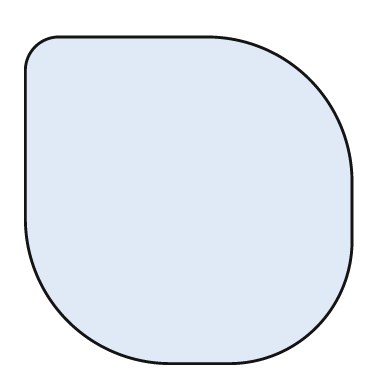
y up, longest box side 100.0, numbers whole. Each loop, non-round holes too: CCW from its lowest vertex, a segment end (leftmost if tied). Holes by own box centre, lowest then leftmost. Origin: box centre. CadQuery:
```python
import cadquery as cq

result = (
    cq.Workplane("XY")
    .moveTo(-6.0, -50.0)
    .lineTo(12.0, -50.0)
    .threePointArc((39.0, -39.0), (50.0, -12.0))
    .lineTo(50.0, 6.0)
    .threePointArc((37.0, 37.0), (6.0, 50.0))
    .lineTo(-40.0, 50.0)
    .threePointArc((-47.0, 47.0), (-50.0, 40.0))
    .lineTo(-50.0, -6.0)
    .threePointArc((-37.0, -37.0), (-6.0, -50.0))
    .close()
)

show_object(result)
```